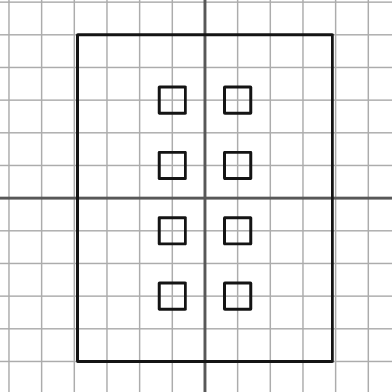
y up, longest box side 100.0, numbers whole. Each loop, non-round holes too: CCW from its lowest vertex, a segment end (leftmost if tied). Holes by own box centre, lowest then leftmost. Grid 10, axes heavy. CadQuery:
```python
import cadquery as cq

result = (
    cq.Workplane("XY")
    .moveTo(-39.0, -50.0)
    .lineTo(39.0, -50.0)
    .lineTo(39.0, 50.0)
    .lineTo(-39.0, 50.0)
    .close()
    .moveTo(-14.0, -34.0)
    .lineTo(-6.0, -34.0)
    .lineTo(-6.0, -26.0)
    .lineTo(-14.0, -26.0)
    .close()
    .moveTo(6.0, -34.0)
    .lineTo(14.0, -34.0)
    .lineTo(14.0, -26.0)
    .lineTo(6.0, -26.0)
    .close()
    .moveTo(-14.0, -14.0)
    .lineTo(-6.0, -14.0)
    .lineTo(-6.0, -6.0)
    .lineTo(-14.0, -6.0)
    .close()
    .moveTo(6.0, -14.0)
    .lineTo(14.0, -14.0)
    .lineTo(14.0, -6.0)
    .lineTo(6.0, -6.0)
    .close()
    .moveTo(-14.0, 6.0)
    .lineTo(-6.0, 6.0)
    .lineTo(-6.0, 14.0)
    .lineTo(-14.0, 14.0)
    .close()
    .moveTo(6.0, 6.0)
    .lineTo(14.0, 6.0)
    .lineTo(14.0, 14.0)
    .lineTo(6.0, 14.0)
    .close()
    .moveTo(-14.0, 26.0)
    .lineTo(-6.0, 26.0)
    .lineTo(-6.0, 34.0)
    .lineTo(-14.0, 34.0)
    .close()
    .moveTo(6.0, 26.0)
    .lineTo(14.0, 26.0)
    .lineTo(14.0, 34.0)
    .lineTo(6.0, 34.0)
    .close()
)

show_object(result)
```